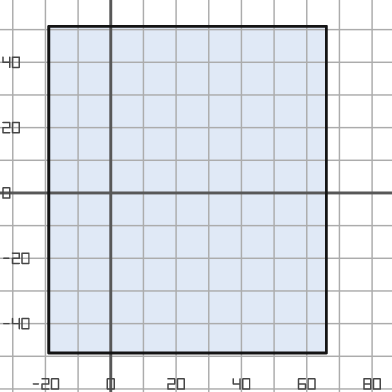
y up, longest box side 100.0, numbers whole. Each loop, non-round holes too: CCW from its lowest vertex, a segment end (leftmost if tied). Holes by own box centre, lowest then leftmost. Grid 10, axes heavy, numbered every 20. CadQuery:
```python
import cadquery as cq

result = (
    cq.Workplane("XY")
    .moveTo(-19.0, -49.0)
    .lineTo(66.0, -49.0)
    .lineTo(66.0, 51.0)
    .lineTo(-19.0, 51.0)
    .close()
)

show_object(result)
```